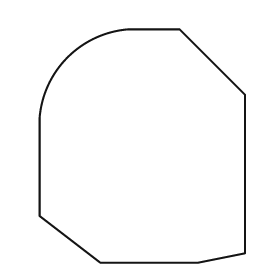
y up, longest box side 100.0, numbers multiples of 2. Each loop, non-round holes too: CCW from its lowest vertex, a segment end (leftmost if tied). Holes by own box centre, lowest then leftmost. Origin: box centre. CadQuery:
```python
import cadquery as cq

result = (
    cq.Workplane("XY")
    .moveTo(-18.0, -50.0)
    .lineTo(24.0, -50.0)
    .lineTo(44.0, -46.0)
    .lineTo(44.0, 22.0)
    .lineTo(16.0, 50.0)
    .lineTo(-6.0, 50.0)
    .threePointArc((-32.0, 38.0), (-44.0, 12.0))
    .lineTo(-44.0, -30.0)
    .close()
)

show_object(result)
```